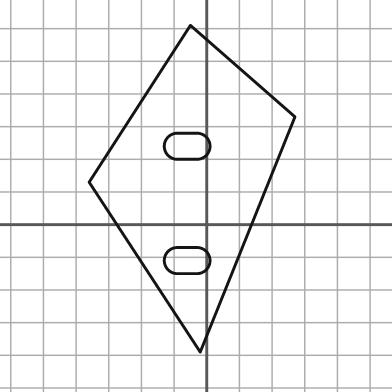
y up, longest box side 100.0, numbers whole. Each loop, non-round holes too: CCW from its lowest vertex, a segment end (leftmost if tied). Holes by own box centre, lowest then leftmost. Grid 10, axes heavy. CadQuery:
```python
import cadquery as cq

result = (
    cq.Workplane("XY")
    .moveTo(-2.0, -39.0)
    .lineTo(27.0, 33.0)
    .lineTo(-5.0, 61.0)
    .lineTo(-36.0, 13.0)
    .close()
    .moveTo(-9.0, -15.0)
    .lineTo(-3.0, -15.0)
    .threePointArc((1.0, -11.0), (-3.0, -7.0))
    .lineTo(-9.0, -7.0)
    .threePointArc((-13.0, -11.0), (-9.0, -15.0))
    .close()
    .moveTo(-9.0, 20.0)
    .lineTo(-3.0, 20.0)
    .threePointArc((1.0, 24.0), (-3.0, 28.0))
    .lineTo(-9.0, 28.0)
    .threePointArc((-13.0, 24.0), (-9.0, 20.0))
    .close()
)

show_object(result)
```